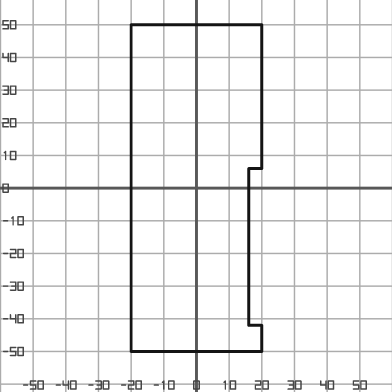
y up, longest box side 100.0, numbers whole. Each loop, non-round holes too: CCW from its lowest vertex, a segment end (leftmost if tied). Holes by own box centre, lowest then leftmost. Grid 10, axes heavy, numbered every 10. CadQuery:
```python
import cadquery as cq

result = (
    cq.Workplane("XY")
    .moveTo(-20.0, -50.0)
    .lineTo(20.0, -50.0)
    .lineTo(20.0, -42.0)
    .lineTo(16.0, -42.0)
    .lineTo(16.0, 6.0)
    .lineTo(20.0, 6.0)
    .lineTo(20.0, 50.0)
    .lineTo(-20.0, 50.0)
    .close()
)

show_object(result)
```